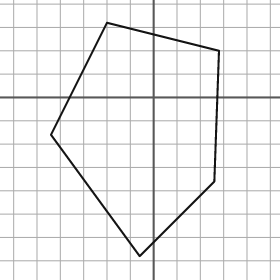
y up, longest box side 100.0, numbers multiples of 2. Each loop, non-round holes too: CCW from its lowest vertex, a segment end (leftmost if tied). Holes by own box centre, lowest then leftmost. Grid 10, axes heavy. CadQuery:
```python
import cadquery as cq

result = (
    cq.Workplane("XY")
    .moveTo(-6.0, -68.0)
    .lineTo(26.0, -36.0)
    .lineTo(28.0, 20.0)
    .lineTo(-20.0, 32.0)
    .lineTo(-44.0, -16.0)
    .close()
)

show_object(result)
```